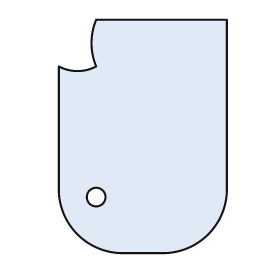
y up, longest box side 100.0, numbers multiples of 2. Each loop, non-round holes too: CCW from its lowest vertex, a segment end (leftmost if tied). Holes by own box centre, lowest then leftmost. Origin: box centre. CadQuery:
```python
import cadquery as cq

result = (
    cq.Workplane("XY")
    .moveTo(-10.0, -50.0)
    .lineTo(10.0, -50.0)
    .threePointArc((28.0, -42.0), (36.0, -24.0))
    .lineTo(36.0, 50.0)
    .lineTo(-20.0, 50.0)
    .threePointArc((-22.0, 40.0), (-20.0, 30.0))
    .threePointArc((-28.0, 28.0), (-36.0, 30.0))
    .lineTo(-36.0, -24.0)
    .threePointArc((-28.0, -42.0), (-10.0, -50.0))
    .close()
    .moveTo(-20.0, -26.0)
    .circle(4.0)
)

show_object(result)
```